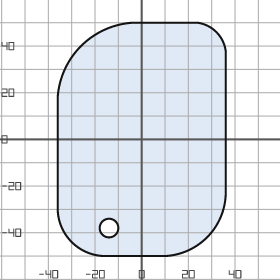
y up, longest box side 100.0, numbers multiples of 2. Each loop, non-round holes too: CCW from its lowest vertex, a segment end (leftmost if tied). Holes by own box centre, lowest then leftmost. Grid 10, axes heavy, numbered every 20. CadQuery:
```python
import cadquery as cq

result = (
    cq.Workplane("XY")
    .moveTo(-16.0, -50.0)
    .lineTo(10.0, -50.0)
    .threePointArc((28.0, -42.0), (36.0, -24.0))
    .lineTo(36.0, 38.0)
    .threePointArc((32.0, 46.0), (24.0, 50.0))
    .lineTo(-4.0, 50.0)
    .threePointArc((-26.0, 40.0), (-36.0, 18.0))
    .lineTo(-36.0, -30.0)
    .threePointArc((-30.0, -44.0), (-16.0, -50.0))
    .close()
    .moveTo(-14.0, -38.0)
    .circle(4.0)
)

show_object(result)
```